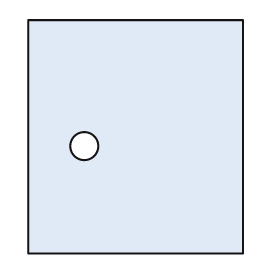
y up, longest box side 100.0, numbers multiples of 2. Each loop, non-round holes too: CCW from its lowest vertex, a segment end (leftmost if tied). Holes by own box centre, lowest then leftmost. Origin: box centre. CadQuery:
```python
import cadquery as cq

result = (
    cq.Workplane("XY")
    .moveTo(-46.0, -50.0)
    .lineTo(46.0, -50.0)
    .lineTo(46.0, 50.0)
    .lineTo(-46.0, 50.0)
    .close()
    .moveTo(-22.0, -4.0)
    .circle(6.0)
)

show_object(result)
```